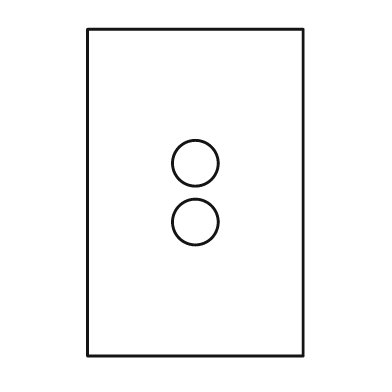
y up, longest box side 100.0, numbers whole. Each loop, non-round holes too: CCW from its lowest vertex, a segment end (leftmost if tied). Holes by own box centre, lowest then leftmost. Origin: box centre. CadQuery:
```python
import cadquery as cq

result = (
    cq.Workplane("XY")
    .moveTo(-33.0, -50.0)
    .lineTo(33.0, -50.0)
    .lineTo(33.0, 50.0)
    .lineTo(-33.0, 50.0)
    .close()
    .moveTo(0.0, -9.0)
    .circle(7.0)
    .moveTo(0.0, 9.0)
    .circle(7.0)
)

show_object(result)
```